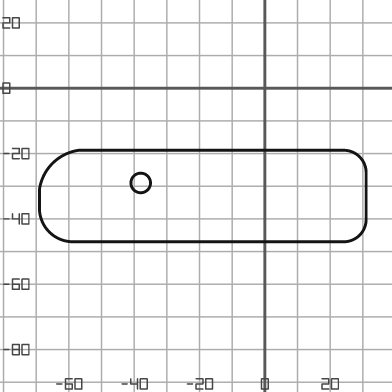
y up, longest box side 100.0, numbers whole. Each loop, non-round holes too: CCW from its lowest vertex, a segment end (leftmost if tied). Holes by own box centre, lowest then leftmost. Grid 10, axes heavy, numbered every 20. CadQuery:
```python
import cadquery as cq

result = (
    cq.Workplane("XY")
    .moveTo(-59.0, -47.0)
    .lineTo(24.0, -47.0)
    .threePointArc((29.0, -45.0), (31.0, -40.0))
    .lineTo(31.0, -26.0)
    .threePointArc((29.0, -21.0), (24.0, -19.0))
    .lineTo(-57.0, -19.0)
    .threePointArc((-65.0, -23.0), (-69.0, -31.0))
    .lineTo(-69.0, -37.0)
    .threePointArc((-66.0, -44.0), (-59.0, -47.0))
    .close()
    .moveTo(-38.0, -29.0)
    .circle(3.0)
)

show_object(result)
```